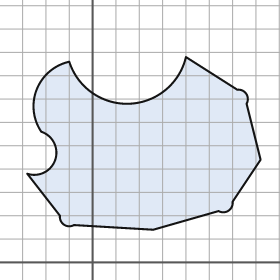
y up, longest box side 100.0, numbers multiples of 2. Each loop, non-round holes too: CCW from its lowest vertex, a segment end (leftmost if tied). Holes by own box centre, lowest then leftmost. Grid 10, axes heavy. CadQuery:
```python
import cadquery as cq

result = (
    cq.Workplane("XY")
    .moveTo(26.0, 14.0)
    .lineTo(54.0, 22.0)
    .threePointArc((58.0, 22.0), (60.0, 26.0))
    .lineTo(72.0, 44.0)
    .lineTo(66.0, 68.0)
    .threePointArc((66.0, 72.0), (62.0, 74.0))
    .lineTo(40.0, 88.0)
    .threePointArc((16.0, 68.0), (-10.0, 86.0))
    .threePointArc((-24.0, 74.0), (-22.0, 56.0))
    .threePointArc((-16.0, 44.0), (-28.0, 38.0))
    .lineTo(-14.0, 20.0)
    .threePointArc((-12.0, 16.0), (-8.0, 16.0))
    .close()
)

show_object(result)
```